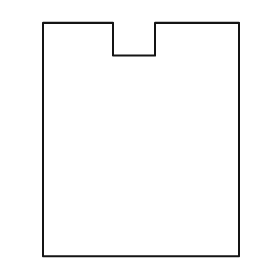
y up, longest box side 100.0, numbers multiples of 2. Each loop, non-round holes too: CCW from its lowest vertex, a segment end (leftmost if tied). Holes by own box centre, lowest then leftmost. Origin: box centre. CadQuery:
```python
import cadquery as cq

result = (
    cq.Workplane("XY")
    .moveTo(-42.0, -50.0)
    .lineTo(42.0, -50.0)
    .lineTo(42.0, 50.0)
    .lineTo(6.0, 50.0)
    .lineTo(6.0, 36.0)
    .lineTo(-12.0, 36.0)
    .lineTo(-12.0, 50.0)
    .lineTo(-42.0, 50.0)
    .close()
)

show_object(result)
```